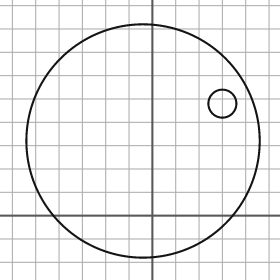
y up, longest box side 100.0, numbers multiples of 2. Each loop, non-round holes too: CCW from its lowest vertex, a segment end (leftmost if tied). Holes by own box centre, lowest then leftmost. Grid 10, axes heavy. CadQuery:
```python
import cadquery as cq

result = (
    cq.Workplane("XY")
    .moveTo(-4.0, 32.0)
    .circle(50.0)
    .moveTo(30.0, 48.0)
    .circle(6.0)
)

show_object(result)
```